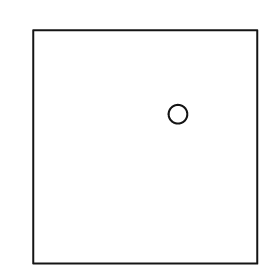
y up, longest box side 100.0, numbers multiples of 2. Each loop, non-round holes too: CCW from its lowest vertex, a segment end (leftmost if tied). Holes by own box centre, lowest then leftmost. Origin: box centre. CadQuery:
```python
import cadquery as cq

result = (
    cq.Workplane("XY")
    .moveTo(-48.0, -50.0)
    .lineTo(48.0, -50.0)
    .lineTo(48.0, 50.0)
    .lineTo(-48.0, 50.0)
    .close()
    .moveTo(14.0, 14.0)
    .circle(4.0)
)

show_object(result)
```